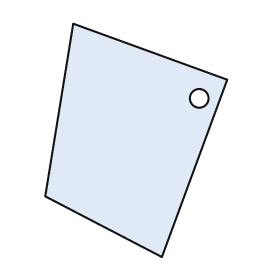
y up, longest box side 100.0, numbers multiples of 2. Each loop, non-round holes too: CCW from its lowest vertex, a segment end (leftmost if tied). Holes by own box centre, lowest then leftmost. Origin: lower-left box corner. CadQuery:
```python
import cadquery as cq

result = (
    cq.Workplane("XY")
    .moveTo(50.0, 0.0)
    .lineTo(78.0, 76.0)
    .lineTo(12.0, 100.0)
    .lineTo(0.0, 26.0)
    .close()
    .moveTo(66.0, 68.0)
    .circle(4.0)
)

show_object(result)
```